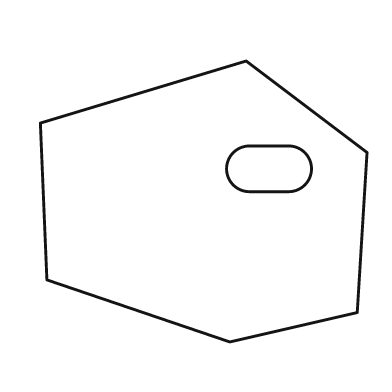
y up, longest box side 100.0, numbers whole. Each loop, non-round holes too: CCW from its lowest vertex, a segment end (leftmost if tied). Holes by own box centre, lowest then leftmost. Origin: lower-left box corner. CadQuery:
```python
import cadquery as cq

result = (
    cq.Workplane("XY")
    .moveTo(58.0, 0.0)
    .lineTo(97.0, 9.0)
    .lineTo(100.0, 58.0)
    .lineTo(63.0, 86.0)
    .lineTo(0.0, 67.0)
    .lineTo(2.0, 19.0)
    .close()
    .moveTo(64.0, 46.0)
    .lineTo(76.0, 46.0)
    .threePointArc((83.0, 53.0), (76.0, 60.0))
    .lineTo(64.0, 60.0)
    .threePointArc((57.0, 53.0), (64.0, 46.0))
    .close()
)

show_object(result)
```